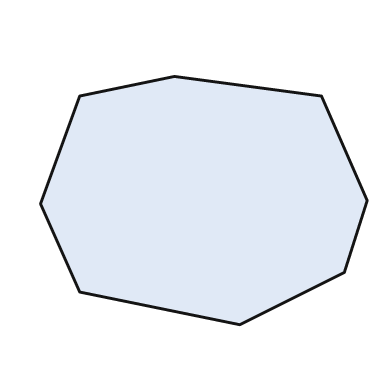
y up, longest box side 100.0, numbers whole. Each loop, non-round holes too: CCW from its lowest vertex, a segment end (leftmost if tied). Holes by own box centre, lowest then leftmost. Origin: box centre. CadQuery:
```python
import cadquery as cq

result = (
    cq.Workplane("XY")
    .moveTo(11.0, -38.0)
    .lineTo(43.0, -22.0)
    .lineTo(50.0, 0.0)
    .lineTo(36.0, 32.0)
    .lineTo(-9.0, 38.0)
    .lineTo(-38.0, 32.0)
    .lineTo(-50.0, -1.0)
    .lineTo(-38.0, -28.0)
    .close()
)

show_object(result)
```